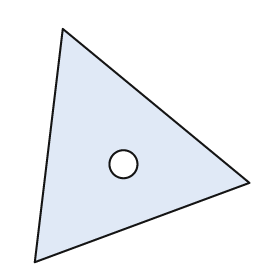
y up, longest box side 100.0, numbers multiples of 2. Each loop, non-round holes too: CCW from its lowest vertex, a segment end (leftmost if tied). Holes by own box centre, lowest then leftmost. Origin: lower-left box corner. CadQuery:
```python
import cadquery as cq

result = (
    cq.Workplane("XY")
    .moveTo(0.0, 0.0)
    .lineTo(92.0, 34.0)
    .lineTo(12.0, 100.0)
    .close()
    .moveTo(38.0, 42.0)
    .circle(6.0)
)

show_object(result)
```